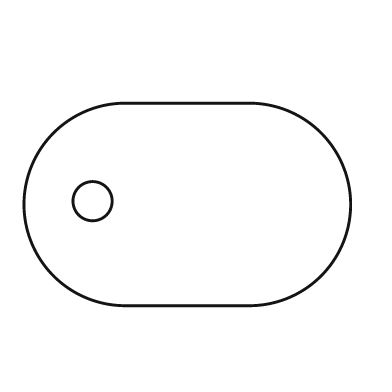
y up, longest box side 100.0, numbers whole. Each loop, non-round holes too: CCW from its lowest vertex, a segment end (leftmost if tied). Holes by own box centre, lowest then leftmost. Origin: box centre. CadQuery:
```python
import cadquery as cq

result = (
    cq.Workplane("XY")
    .moveTo(-19.0, -31.0)
    .lineTo(19.0, -31.0)
    .threePointArc((50.0, 0.0), (19.0, 31.0))
    .lineTo(-19.0, 31.0)
    .threePointArc((-50.0, 0.0), (-19.0, -31.0))
    .close()
    .moveTo(-29.0, 1.0)
    .circle(6.0)
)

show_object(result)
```